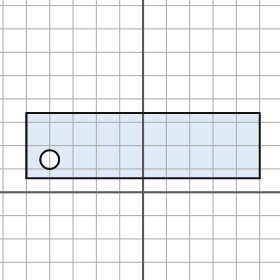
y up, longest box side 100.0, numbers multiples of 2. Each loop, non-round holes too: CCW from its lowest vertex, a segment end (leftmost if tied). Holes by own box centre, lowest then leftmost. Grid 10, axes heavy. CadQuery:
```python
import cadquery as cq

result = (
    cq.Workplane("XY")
    .moveTo(-50.0, 6.0)
    .lineTo(50.0, 6.0)
    .lineTo(50.0, 34.0)
    .lineTo(-50.0, 34.0)
    .close()
    .moveTo(-40.0, 14.0)
    .circle(4.0)
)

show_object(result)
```